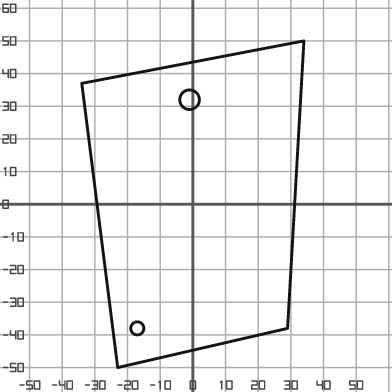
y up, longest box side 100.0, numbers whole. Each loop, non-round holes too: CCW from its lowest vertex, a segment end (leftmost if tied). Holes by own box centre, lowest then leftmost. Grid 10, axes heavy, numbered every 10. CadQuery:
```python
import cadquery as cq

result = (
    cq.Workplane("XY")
    .moveTo(-23.0, -50.0)
    .lineTo(29.0, -38.0)
    .lineTo(34.0, 50.0)
    .lineTo(-34.0, 37.0)
    .close()
    .moveTo(-17.0, -38.0)
    .circle(2.0)
    .moveTo(-1.0, 32.0)
    .circle(3.0)
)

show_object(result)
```